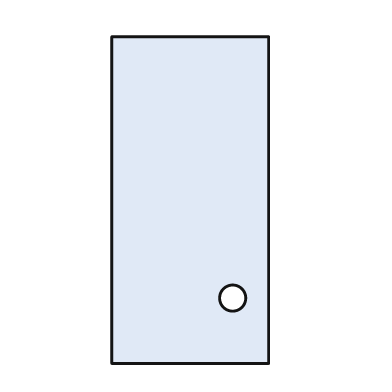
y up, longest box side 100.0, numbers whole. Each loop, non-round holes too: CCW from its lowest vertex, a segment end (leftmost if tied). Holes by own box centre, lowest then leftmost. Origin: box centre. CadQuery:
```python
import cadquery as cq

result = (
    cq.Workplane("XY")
    .moveTo(-24.0, -50.0)
    .lineTo(24.0, -50.0)
    .lineTo(24.0, 50.0)
    .lineTo(-24.0, 50.0)
    .close()
    .moveTo(13.0, -30.0)
    .circle(4.0)
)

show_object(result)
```